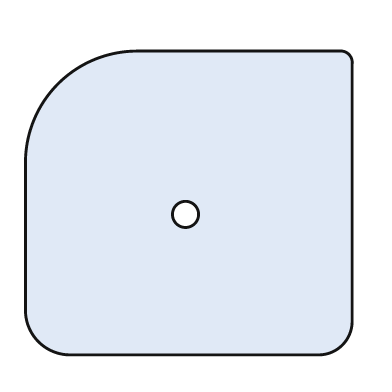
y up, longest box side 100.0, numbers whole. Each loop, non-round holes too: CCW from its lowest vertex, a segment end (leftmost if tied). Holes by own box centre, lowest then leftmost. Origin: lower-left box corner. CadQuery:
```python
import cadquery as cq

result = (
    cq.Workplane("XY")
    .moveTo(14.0, 0.0)
    .lineTo(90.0, 0.0)
    .threePointArc((97.0, 3.0), (100.0, 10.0))
    .lineTo(100.0, 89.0)
    .threePointArc((99.0, 92.0), (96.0, 93.0))
    .lineTo(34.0, 93.0)
    .threePointArc((10.0, 83.0), (0.0, 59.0))
    .lineTo(0.0, 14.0)
    .threePointArc((4.0, 4.0), (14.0, 0.0))
    .close()
    .moveTo(49.0, 43.0)
    .circle(4.0)
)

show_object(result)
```